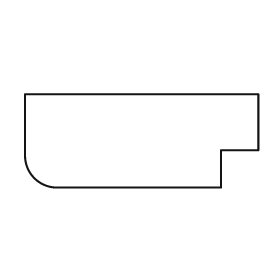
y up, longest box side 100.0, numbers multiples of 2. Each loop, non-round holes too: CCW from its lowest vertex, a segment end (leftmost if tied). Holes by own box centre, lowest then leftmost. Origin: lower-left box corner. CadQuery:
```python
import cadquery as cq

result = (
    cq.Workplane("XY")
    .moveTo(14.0, 0.0)
    .lineTo(84.0, 0.0)
    .lineTo(84.0, 16.0)
    .lineTo(100.0, 16.0)
    .lineTo(100.0, 40.0)
    .lineTo(0.0, 40.0)
    .lineTo(0.0, 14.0)
    .threePointArc((4.0, 4.0), (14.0, 0.0))
    .close()
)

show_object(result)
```